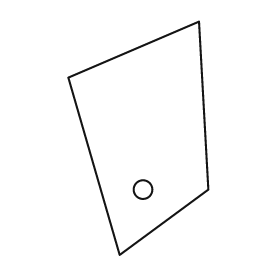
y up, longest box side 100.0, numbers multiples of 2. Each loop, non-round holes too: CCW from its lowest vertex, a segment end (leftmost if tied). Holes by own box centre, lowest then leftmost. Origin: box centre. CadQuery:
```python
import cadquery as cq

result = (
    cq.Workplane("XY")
    .moveTo(-8.0, -50.0)
    .lineTo(30.0, -22.0)
    .lineTo(26.0, 50.0)
    .lineTo(-30.0, 26.0)
    .close()
    .moveTo(2.0, -22.0)
    .circle(4.0)
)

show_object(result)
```